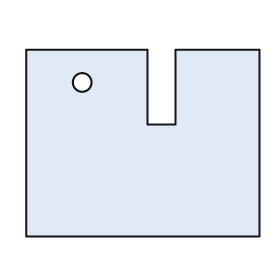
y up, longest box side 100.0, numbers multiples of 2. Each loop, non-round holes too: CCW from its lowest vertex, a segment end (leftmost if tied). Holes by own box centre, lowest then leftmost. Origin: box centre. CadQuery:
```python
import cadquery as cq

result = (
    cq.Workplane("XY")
    .moveTo(-50.0, -40.0)
    .lineTo(50.0, -40.0)
    .lineTo(50.0, 40.0)
    .lineTo(14.0, 40.0)
    .lineTo(14.0, 8.0)
    .lineTo(2.0, 8.0)
    .lineTo(2.0, 40.0)
    .lineTo(-50.0, 40.0)
    .close()
    .moveTo(-26.0, 26.0)
    .circle(4.0)
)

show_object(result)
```